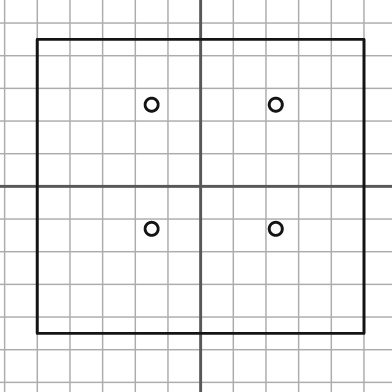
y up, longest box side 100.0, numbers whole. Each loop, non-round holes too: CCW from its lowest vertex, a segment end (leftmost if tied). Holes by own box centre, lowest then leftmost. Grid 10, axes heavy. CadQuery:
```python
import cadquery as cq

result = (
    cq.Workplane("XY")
    .moveTo(-50.0, -45.0)
    .lineTo(50.0, -45.0)
    .lineTo(50.0, 45.0)
    .lineTo(-50.0, 45.0)
    .close()
    .moveTo(-15.0, -13.0)
    .circle(2.0)
    .moveTo(23.0, -13.0)
    .circle(2.0)
    .moveTo(-15.0, 25.0)
    .circle(2.0)
    .moveTo(23.0, 25.0)
    .circle(2.0)
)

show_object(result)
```